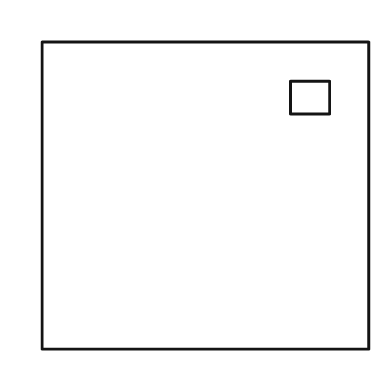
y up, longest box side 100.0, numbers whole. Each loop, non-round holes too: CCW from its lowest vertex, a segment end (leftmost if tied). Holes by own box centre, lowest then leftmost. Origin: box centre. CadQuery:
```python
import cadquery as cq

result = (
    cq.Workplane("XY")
    .moveTo(-50.0, -47.0)
    .lineTo(50.0, -47.0)
    .lineTo(50.0, 47.0)
    .lineTo(-50.0, 47.0)
    .close()
    .moveTo(26.0, 25.0)
    .lineTo(38.0, 25.0)
    .lineTo(38.0, 35.0)
    .lineTo(26.0, 35.0)
    .close()
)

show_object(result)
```